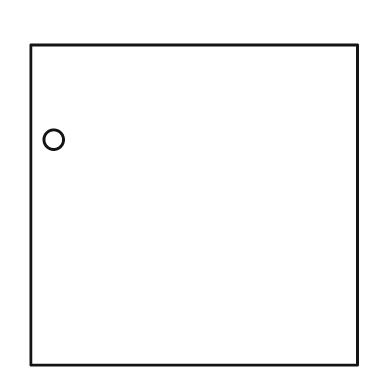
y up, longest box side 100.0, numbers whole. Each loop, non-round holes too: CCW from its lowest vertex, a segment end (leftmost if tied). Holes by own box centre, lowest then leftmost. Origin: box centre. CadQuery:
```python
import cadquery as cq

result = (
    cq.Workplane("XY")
    .moveTo(-50.0, -49.0)
    .lineTo(50.0, -49.0)
    .lineTo(50.0, 49.0)
    .lineTo(-50.0, 49.0)
    .close()
    .moveTo(-43.0, 20.0)
    .circle(3.0)
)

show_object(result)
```